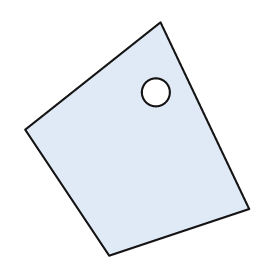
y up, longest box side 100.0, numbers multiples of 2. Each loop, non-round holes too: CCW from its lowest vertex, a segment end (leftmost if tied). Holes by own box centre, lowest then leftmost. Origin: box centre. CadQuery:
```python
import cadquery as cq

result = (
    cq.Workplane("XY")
    .moveTo(-12.0, -50.0)
    .lineTo(48.0, -30.0)
    .lineTo(10.0, 50.0)
    .lineTo(-48.0, 4.0)
    .close()
    .moveTo(8.0, 20.0)
    .circle(6.0)
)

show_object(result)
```